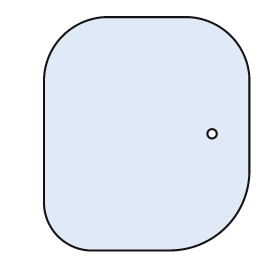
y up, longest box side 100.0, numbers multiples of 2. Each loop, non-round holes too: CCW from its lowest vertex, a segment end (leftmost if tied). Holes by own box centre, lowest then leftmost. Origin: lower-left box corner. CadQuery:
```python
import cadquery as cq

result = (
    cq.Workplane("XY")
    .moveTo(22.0, 0.0)
    .lineTo(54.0, 0.0)
    .threePointArc((78.0, 10.0), (88.0, 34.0))
    .lineTo(88.0, 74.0)
    .threePointArc((80.0, 92.0), (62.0, 100.0))
    .lineTo(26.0, 100.0)
    .threePointArc((8.0, 92.0), (0.0, 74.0))
    .lineTo(0.0, 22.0)
    .threePointArc((6.0, 6.0), (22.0, 0.0))
    .close()
    .moveTo(72.0, 50.0)
    .circle(2.0)
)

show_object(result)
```